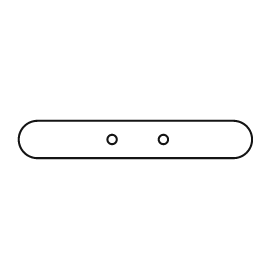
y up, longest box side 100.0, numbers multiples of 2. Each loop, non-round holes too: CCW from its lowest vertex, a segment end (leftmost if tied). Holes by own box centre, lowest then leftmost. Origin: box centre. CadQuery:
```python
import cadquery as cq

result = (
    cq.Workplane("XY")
    .moveTo(-42.0, -8.0)
    .lineTo(42.0, -8.0)
    .threePointArc((50.0, 0.0), (42.0, 8.0))
    .lineTo(-42.0, 8.0)
    .threePointArc((-50.0, 0.0), (-42.0, -8.0))
    .close()
    .moveTo(-10.0, 0.0)
    .circle(2.0)
    .moveTo(12.0, 0.0)
    .circle(2.0)
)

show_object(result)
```